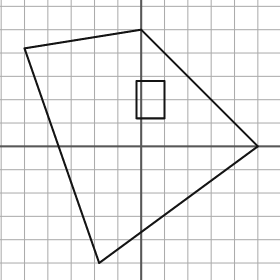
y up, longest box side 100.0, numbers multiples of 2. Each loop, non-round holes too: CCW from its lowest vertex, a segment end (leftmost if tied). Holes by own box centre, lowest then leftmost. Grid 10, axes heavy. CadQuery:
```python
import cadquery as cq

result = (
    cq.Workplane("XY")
    .moveTo(-18.0, -50.0)
    .lineTo(50.0, 0.0)
    .lineTo(0.0, 50.0)
    .lineTo(-50.0, 42.0)
    .close()
    .moveTo(-2.0, 12.0)
    .lineTo(10.0, 12.0)
    .lineTo(10.0, 28.0)
    .lineTo(-2.0, 28.0)
    .close()
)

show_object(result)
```